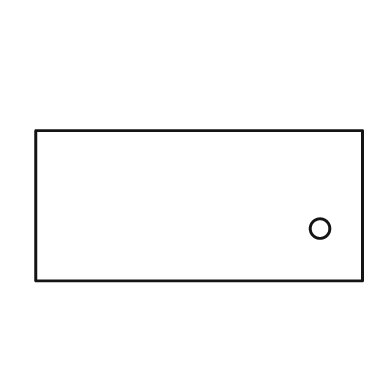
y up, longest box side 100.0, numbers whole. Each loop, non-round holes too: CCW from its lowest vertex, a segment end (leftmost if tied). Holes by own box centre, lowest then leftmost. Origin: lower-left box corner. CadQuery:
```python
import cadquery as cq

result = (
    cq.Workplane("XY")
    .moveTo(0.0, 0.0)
    .lineTo(100.0, 0.0)
    .lineTo(100.0, 46.0)
    .lineTo(0.0, 46.0)
    .close()
    .moveTo(87.0, 16.0)
    .circle(3.0)
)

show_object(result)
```